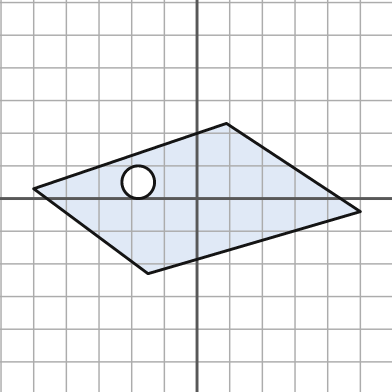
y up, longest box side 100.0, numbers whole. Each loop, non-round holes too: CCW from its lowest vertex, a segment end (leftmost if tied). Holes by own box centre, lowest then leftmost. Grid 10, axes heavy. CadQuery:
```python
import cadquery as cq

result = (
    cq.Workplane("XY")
    .moveTo(-15.0, -23.0)
    .lineTo(50.0, -4.0)
    .lineTo(9.0, 23.0)
    .lineTo(-50.0, 3.0)
    .close()
    .moveTo(-18.0, 5.0)
    .circle(5.0)
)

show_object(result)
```